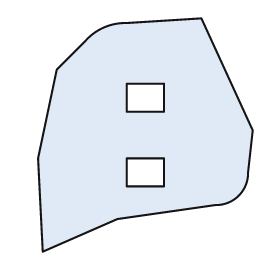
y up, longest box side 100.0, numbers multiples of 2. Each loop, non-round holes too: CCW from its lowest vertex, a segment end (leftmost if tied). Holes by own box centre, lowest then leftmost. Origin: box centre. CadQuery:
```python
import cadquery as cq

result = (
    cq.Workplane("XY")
    .moveTo(-44.0, -50.0)
    .lineTo(-12.0, -36.0)
    .lineTo(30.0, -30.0)
    .threePointArc((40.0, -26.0), (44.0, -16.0))
    .lineTo(46.0, 2.0)
    .lineTo(24.0, 50.0)
    .lineTo(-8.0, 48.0)
    .threePointArc((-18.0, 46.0), (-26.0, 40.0))
    .lineTo(-38.0, 28.0)
    .lineTo(-46.0, -10.0)
    .close()
    .moveTo(-8.0, -22.0)
    .lineTo(8.0, -22.0)
    .lineTo(8.0, -10.0)
    .lineTo(-8.0, -10.0)
    .close()
    .moveTo(-8.0, 10.0)
    .lineTo(8.0, 10.0)
    .lineTo(8.0, 22.0)
    .lineTo(-8.0, 22.0)
    .close()
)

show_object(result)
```